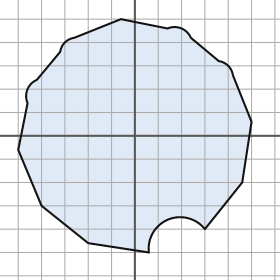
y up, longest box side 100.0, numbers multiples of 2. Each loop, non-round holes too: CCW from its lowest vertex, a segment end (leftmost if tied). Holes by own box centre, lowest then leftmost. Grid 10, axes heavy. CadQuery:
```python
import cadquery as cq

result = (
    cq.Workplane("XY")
    .moveTo(6.0, -50.0)
    .threePointArc((14.0, -36.0), (30.0, -40.0))
    .lineTo(46.0, -20.0)
    .lineTo(50.0, 6.0)
    .lineTo(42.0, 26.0)
    .threePointArc((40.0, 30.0), (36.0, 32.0))
    .lineTo(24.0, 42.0)
    .threePointArc((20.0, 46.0), (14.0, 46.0))
    .lineTo(-6.0, 50.0)
    .lineTo(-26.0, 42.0)
    .threePointArc((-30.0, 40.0), (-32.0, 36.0))
    .lineTo(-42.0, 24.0)
    .threePointArc((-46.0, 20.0), (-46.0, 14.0))
    .lineTo(-50.0, -6.0)
    .lineTo(-40.0, -30.0)
    .lineTo(-20.0, -46.0)
    .close()
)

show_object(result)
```